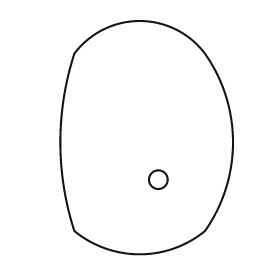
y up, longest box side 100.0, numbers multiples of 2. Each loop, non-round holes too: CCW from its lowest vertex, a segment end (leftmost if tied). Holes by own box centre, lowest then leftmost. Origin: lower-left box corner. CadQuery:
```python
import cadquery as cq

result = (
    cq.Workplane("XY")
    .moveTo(6.0, 10.0)
    .threePointArc((34.0, 0.0), (62.0, 10.0))
    .threePointArc((74.0, 48.0), (62.0, 86.0))
    .threePointArc((34.0, 100.0), (6.0, 86.0))
    .threePointArc((0.0, 48.0), (6.0, 10.0))
    .close()
    .moveTo(42.0, 32.0)
    .circle(4.0)
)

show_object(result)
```